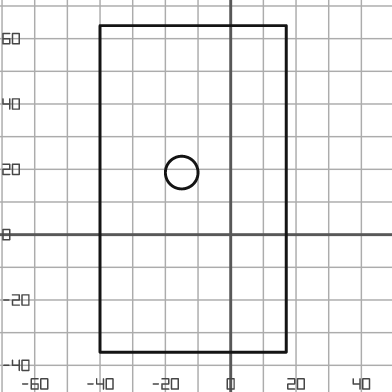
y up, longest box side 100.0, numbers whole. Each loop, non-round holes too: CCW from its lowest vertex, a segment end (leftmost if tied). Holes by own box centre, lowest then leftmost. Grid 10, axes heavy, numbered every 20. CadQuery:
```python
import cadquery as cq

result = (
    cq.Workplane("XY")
    .moveTo(-40.0, -36.0)
    .lineTo(17.0, -36.0)
    .lineTo(17.0, 64.0)
    .lineTo(-40.0, 64.0)
    .close()
    .moveTo(-15.0, 19.0)
    .circle(5.0)
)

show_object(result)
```